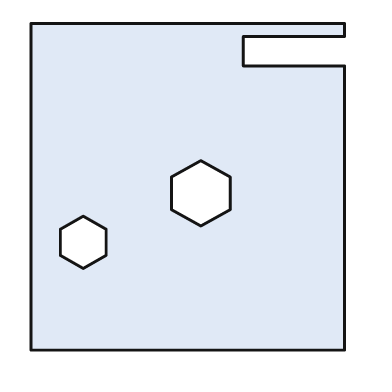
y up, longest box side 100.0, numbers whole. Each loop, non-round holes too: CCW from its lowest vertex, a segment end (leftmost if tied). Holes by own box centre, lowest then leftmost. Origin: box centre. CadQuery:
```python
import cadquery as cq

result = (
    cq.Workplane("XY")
    .moveTo(-48.0, -50.0)
    .lineTo(48.0, -50.0)
    .lineTo(48.0, 37.0)
    .lineTo(17.0, 37.0)
    .lineTo(17.0, 46.0)
    .lineTo(48.0, 46.0)
    .lineTo(48.0, 50.0)
    .lineTo(-48.0, 50.0)
    .close()
    .moveTo(-32.0, -25.0)
    .lineTo(-25.0, -21.0)
    .lineTo(-25.0, -13.0)
    .lineTo(-32.0, -9.0)
    .lineTo(-39.0, -13.0)
    .lineTo(-39.0, -21.0)
    .close()
    .moveTo(4.0, -12.0)
    .lineTo(13.0, -7.0)
    .lineTo(13.0, 3.0)
    .lineTo(4.0, 8.0)
    .lineTo(-5.0, 3.0)
    .lineTo(-5.0, -7.0)
    .close()
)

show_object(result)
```